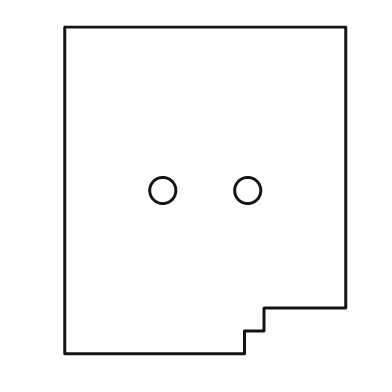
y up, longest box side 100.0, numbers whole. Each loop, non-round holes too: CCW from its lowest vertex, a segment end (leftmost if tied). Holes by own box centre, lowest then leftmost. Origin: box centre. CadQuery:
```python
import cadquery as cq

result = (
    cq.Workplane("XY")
    .moveTo(-43.0, -50.0)
    .lineTo(12.0, -50.0)
    .lineTo(12.0, -43.0)
    .lineTo(18.0, -43.0)
    .lineTo(18.0, -36.0)
    .lineTo(43.0, -36.0)
    .lineTo(43.0, 50.0)
    .lineTo(-43.0, 50.0)
    .close()
    .moveTo(-13.0, 0.0)
    .circle(4.0)
    .moveTo(13.0, 0.0)
    .circle(4.0)
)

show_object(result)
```